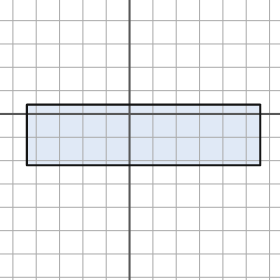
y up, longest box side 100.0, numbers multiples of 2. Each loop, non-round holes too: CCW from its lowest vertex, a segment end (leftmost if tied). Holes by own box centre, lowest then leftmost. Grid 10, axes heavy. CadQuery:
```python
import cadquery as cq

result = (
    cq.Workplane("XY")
    .moveTo(-44.0, -22.0)
    .lineTo(56.0, -22.0)
    .lineTo(56.0, 4.0)
    .lineTo(-44.0, 4.0)
    .close()
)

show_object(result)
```